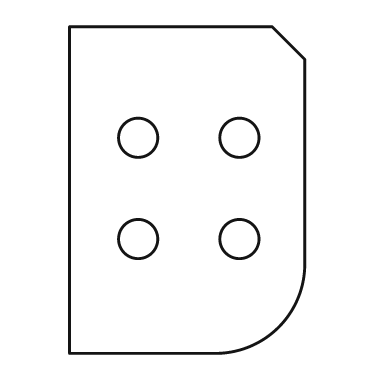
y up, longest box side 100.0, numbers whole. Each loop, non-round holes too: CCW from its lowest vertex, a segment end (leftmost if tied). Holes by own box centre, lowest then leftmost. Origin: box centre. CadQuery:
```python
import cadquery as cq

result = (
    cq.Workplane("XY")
    .moveTo(-36.0, -50.0)
    .lineTo(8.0, -50.0)
    .threePointArc((28.0, -42.0), (36.0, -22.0))
    .lineTo(36.0, 40.0)
    .lineTo(26.0, 50.0)
    .lineTo(-36.0, 50.0)
    .close()
    .moveTo(-15.0, -15.0)
    .circle(6.0)
    .moveTo(16.0, -15.0)
    .circle(6.0)
    .moveTo(-15.0, 16.0)
    .circle(6.0)
    .moveTo(16.0, 16.0)
    .circle(6.0)
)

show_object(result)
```